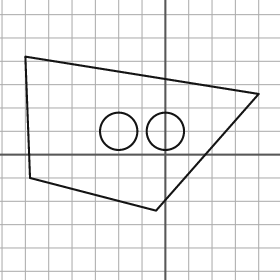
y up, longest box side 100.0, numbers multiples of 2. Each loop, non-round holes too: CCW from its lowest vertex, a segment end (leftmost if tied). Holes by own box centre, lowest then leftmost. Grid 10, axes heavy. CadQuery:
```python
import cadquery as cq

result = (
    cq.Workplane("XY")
    .moveTo(-4.0, -24.0)
    .lineTo(40.0, 26.0)
    .lineTo(-60.0, 42.0)
    .lineTo(-58.0, -10.0)
    .close()
    .moveTo(-20.0, 10.0)
    .circle(8.0)
    .moveTo(0.0, 10.0)
    .circle(8.0)
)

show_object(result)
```